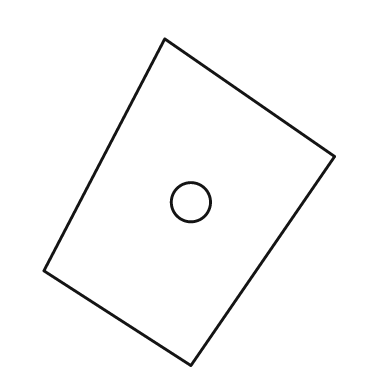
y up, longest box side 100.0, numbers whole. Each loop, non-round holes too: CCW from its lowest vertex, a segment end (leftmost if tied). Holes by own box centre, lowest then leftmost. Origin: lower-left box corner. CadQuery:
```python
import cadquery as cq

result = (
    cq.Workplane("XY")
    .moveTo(45.0, 0.0)
    .lineTo(89.0, 64.0)
    .lineTo(37.0, 100.0)
    .lineTo(0.0, 29.0)
    .close()
    .moveTo(45.0, 50.0)
    .circle(6.0)
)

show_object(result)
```